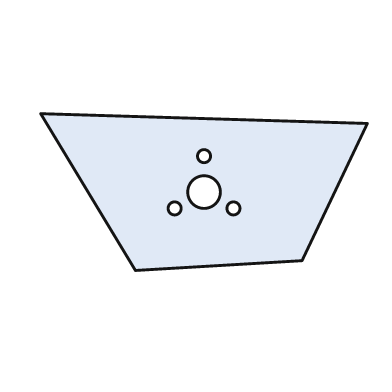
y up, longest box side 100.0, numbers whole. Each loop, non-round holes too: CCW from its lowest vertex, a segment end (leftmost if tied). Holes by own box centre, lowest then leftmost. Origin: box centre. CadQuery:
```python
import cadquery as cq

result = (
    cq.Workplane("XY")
    .moveTo(-21.0, -24.0)
    .lineTo(30.0, -21.0)
    .lineTo(50.0, 21.0)
    .lineTo(-50.0, 24.0)
    .close()
    .moveTo(-9.0, -5.0)
    .circle(2.0)
    .moveTo(9.0, -5.0)
    .circle(2.0)
    .moveTo(0.0, 0.0)
    .circle(5.0)
    .moveTo(0.0, 11.0)
    .circle(2.0)
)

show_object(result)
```